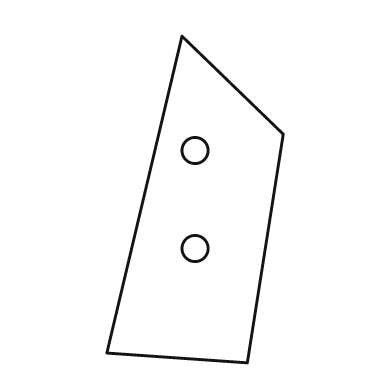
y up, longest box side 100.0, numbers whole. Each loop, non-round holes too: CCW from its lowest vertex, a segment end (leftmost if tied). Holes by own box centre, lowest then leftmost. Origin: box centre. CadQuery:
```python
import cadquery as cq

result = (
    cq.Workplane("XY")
    .moveTo(16.0, -50.0)
    .lineTo(27.0, 20.0)
    .lineTo(-4.0, 50.0)
    .lineTo(-27.0, -47.0)
    .close()
    .moveTo(0.0, -15.0)
    .circle(4.0)
    .moveTo(0.0, 15.0)
    .circle(4.0)
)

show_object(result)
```